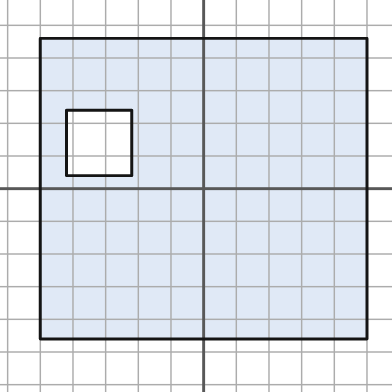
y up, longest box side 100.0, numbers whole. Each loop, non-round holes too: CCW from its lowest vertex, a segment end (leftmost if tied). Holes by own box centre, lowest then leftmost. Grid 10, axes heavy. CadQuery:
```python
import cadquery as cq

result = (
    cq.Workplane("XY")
    .moveTo(-50.0, -46.0)
    .lineTo(50.0, -46.0)
    .lineTo(50.0, 46.0)
    .lineTo(-50.0, 46.0)
    .close()
    .moveTo(-42.0, 4.0)
    .lineTo(-22.0, 4.0)
    .lineTo(-22.0, 24.0)
    .lineTo(-42.0, 24.0)
    .close()
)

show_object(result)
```